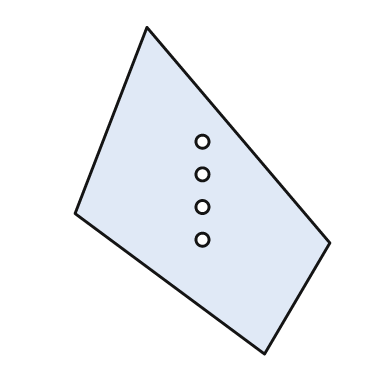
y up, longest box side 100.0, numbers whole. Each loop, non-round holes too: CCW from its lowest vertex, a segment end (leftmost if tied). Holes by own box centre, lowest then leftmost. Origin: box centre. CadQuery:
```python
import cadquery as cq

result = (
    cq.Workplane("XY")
    .moveTo(19.0, -50.0)
    .lineTo(39.0, -16.0)
    .lineTo(-17.0, 50.0)
    .lineTo(-39.0, -7.0)
    .close()
    .moveTo(0.0, -15.0)
    .circle(2.0)
    .moveTo(0.0, -5.0)
    .circle(2.0)
    .moveTo(0.0, 5.0)
    .circle(2.0)
    .moveTo(0.0, 15.0)
    .circle(2.0)
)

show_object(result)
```